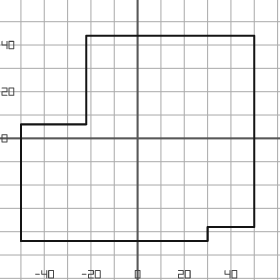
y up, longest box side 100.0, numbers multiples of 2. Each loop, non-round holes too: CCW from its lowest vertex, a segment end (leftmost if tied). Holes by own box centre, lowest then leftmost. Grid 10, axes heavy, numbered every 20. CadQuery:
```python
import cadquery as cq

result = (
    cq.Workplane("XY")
    .moveTo(-50.0, -44.0)
    .lineTo(30.0, -44.0)
    .lineTo(30.0, -38.0)
    .lineTo(50.0, -38.0)
    .lineTo(50.0, 44.0)
    .lineTo(-22.0, 44.0)
    .lineTo(-22.0, 6.0)
    .lineTo(-50.0, 6.0)
    .close()
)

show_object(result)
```